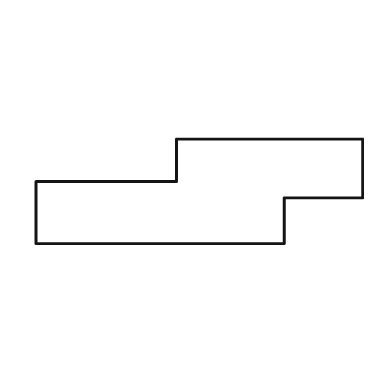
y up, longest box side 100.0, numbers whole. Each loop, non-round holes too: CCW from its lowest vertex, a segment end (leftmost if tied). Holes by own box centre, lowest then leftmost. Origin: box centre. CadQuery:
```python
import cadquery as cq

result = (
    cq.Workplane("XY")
    .moveTo(-50.0, -16.0)
    .lineTo(26.0, -16.0)
    .lineTo(26.0, -2.0)
    .lineTo(50.0, -2.0)
    .lineTo(50.0, 16.0)
    .lineTo(-7.0, 16.0)
    .lineTo(-7.0, 3.0)
    .lineTo(-50.0, 3.0)
    .close()
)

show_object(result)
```